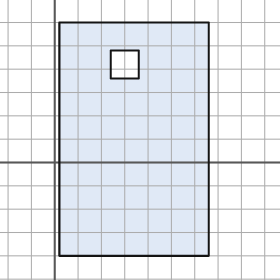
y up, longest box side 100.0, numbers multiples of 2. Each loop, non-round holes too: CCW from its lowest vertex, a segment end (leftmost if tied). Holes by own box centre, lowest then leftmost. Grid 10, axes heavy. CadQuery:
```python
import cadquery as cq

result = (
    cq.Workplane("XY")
    .moveTo(2.0, -40.0)
    .lineTo(66.0, -40.0)
    .lineTo(66.0, 60.0)
    .lineTo(2.0, 60.0)
    .close()
    .moveTo(24.0, 36.0)
    .lineTo(36.0, 36.0)
    .lineTo(36.0, 48.0)
    .lineTo(24.0, 48.0)
    .close()
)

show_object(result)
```